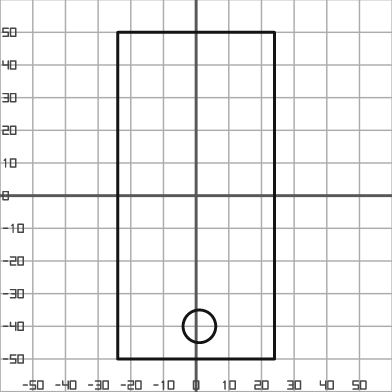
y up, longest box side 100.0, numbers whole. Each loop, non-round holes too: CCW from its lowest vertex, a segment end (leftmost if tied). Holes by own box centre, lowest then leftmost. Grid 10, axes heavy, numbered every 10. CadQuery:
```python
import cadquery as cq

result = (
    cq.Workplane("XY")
    .moveTo(-24.0, -50.0)
    .lineTo(24.0, -50.0)
    .lineTo(24.0, 50.0)
    .lineTo(-24.0, 50.0)
    .close()
    .moveTo(1.0, -40.0)
    .circle(5.0)
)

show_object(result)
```